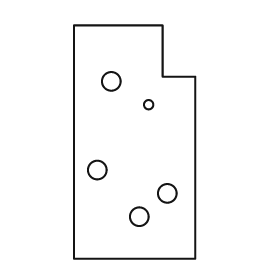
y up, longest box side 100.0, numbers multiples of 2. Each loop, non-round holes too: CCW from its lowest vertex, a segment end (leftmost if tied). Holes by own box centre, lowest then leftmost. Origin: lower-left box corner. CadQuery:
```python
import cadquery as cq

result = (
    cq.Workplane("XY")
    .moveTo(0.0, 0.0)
    .lineTo(52.0, 0.0)
    .lineTo(52.0, 78.0)
    .lineTo(38.0, 78.0)
    .lineTo(38.0, 100.0)
    .lineTo(0.0, 100.0)
    .close()
    .moveTo(28.0, 18.0)
    .circle(4.0)
    .moveTo(40.0, 28.0)
    .circle(4.0)
    .moveTo(10.0, 38.0)
    .circle(4.0)
    .moveTo(32.0, 66.0)
    .circle(2.0)
    .moveTo(16.0, 76.0)
    .circle(4.0)
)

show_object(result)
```